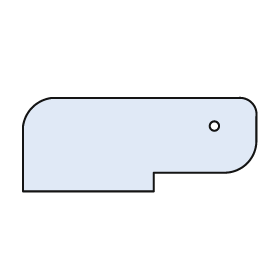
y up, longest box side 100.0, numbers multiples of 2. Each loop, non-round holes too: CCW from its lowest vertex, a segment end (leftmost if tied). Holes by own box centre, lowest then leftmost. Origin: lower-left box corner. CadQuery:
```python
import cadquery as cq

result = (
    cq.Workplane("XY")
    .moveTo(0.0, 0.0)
    .lineTo(56.0, 0.0)
    .lineTo(56.0, 8.0)
    .lineTo(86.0, 8.0)
    .threePointArc((96.0, 12.0), (100.0, 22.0))
    .lineTo(100.0, 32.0)
    .threePointArc((98.0, 38.0), (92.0, 40.0))
    .lineTo(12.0, 40.0)
    .threePointArc((4.0, 36.0), (0.0, 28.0))
    .close()
    .moveTo(82.0, 28.0)
    .circle(2.0)
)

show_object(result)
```